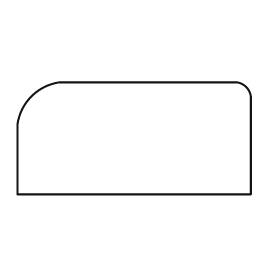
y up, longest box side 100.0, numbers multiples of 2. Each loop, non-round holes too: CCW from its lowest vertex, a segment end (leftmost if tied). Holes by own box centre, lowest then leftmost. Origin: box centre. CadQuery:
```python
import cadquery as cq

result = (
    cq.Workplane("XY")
    .moveTo(-50.0, -24.0)
    .lineTo(50.0, -24.0)
    .lineTo(50.0, 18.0)
    .threePointArc((48.0, 22.0), (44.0, 24.0))
    .lineTo(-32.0, 24.0)
    .threePointArc((-44.0, 18.0), (-50.0, 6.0))
    .close()
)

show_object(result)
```